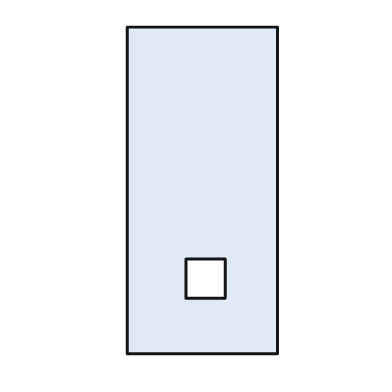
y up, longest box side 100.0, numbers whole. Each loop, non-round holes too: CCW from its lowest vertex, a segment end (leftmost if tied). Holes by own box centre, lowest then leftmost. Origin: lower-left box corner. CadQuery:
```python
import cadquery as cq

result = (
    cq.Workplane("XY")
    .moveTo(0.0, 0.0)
    .lineTo(46.0, 0.0)
    .lineTo(46.0, 100.0)
    .lineTo(0.0, 100.0)
    .close()
    .moveTo(18.0, 17.0)
    .lineTo(30.0, 17.0)
    .lineTo(30.0, 29.0)
    .lineTo(18.0, 29.0)
    .close()
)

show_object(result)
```